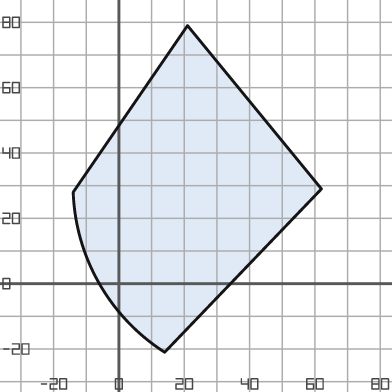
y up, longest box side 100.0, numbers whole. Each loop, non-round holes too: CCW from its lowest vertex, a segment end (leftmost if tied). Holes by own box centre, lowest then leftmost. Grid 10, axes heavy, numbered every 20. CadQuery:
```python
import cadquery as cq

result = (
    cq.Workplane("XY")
    .moveTo(14.0, -21.0)
    .lineTo(62.0, 29.0)
    .lineTo(21.0, 79.0)
    .lineTo(-14.0, 28.0)
    .threePointArc((-6.0, 0.0), (14.0, -21.0))
    .close()
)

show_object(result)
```